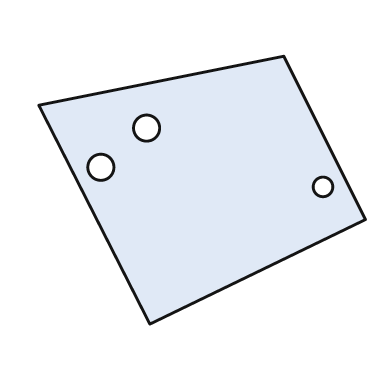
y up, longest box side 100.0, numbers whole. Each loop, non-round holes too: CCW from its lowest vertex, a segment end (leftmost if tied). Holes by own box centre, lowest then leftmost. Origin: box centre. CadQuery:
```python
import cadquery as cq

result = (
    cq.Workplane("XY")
    .moveTo(-16.0, -41.0)
    .lineTo(50.0, -9.0)
    .lineTo(25.0, 41.0)
    .lineTo(-50.0, 26.0)
    .close()
    .moveTo(37.0, 1.0)
    .circle(3.0)
    .moveTo(-31.0, 7.0)
    .circle(4.0)
    .moveTo(-17.0, 19.0)
    .circle(4.0)
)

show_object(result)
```